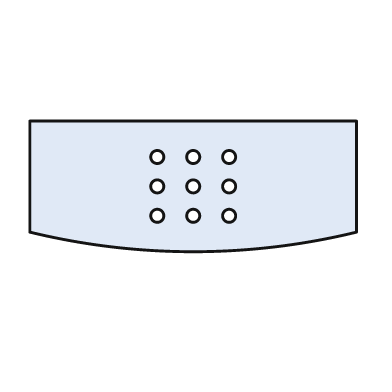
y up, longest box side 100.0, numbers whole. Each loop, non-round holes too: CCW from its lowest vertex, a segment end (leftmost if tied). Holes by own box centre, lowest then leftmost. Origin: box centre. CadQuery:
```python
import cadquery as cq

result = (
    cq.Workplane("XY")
    .moveTo(-50.0, -14.0)
    .threePointArc((0.0, -20.0), (50.0, -14.0))
    .lineTo(50.0, 20.0)
    .lineTo(-50.0, 20.0)
    .close()
    .moveTo(-11.0, -9.0)
    .circle(2.0)
    .moveTo(0.0, -9.0)
    .circle(2.0)
    .moveTo(11.0, -9.0)
    .circle(2.0)
    .moveTo(-11.0, 0.0)
    .circle(2.0)
    .moveTo(0.0, 0.0)
    .circle(2.0)
    .moveTo(11.0, 0.0)
    .circle(2.0)
    .moveTo(-11.0, 9.0)
    .circle(2.0)
    .moveTo(0.0, 9.0)
    .circle(2.0)
    .moveTo(11.0, 9.0)
    .circle(2.0)
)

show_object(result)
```